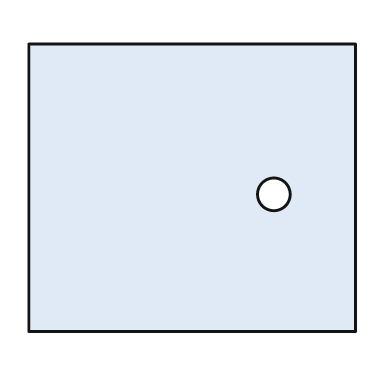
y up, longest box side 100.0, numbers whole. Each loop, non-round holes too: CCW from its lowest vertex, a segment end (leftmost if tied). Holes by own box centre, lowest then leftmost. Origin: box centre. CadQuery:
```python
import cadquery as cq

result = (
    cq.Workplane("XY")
    .moveTo(-50.0, -44.0)
    .lineTo(50.0, -44.0)
    .lineTo(50.0, 44.0)
    .lineTo(-50.0, 44.0)
    .close()
    .moveTo(25.0, -2.0)
    .circle(5.0)
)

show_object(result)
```